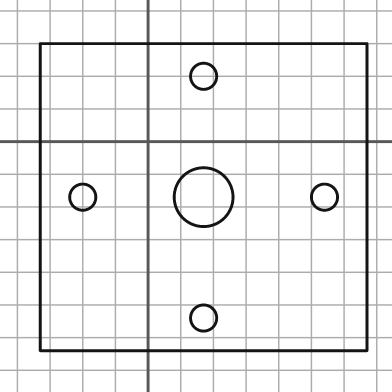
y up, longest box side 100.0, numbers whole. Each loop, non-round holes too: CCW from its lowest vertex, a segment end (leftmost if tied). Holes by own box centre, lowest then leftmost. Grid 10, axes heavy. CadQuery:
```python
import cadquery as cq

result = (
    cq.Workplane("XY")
    .moveTo(-33.0, -64.0)
    .lineTo(67.0, -64.0)
    .lineTo(67.0, 30.0)
    .lineTo(-33.0, 30.0)
    .close()
    .moveTo(17.0, -54.0)
    .circle(4.0)
    .moveTo(-20.0, -17.0)
    .circle(4.0)
    .moveTo(17.0, -17.0)
    .circle(9.0)
    .moveTo(54.0, -17.0)
    .circle(4.0)
    .moveTo(17.0, 20.0)
    .circle(4.0)
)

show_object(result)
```